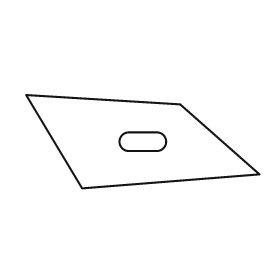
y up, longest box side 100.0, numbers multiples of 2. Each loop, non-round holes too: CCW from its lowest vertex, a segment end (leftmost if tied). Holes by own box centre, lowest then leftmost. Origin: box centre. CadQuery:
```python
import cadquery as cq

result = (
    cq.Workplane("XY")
    .moveTo(-26.0, -20.0)
    .lineTo(50.0, -14.0)
    .lineTo(16.0, 16.0)
    .lineTo(-50.0, 20.0)
    .close()
    .moveTo(-6.0, -4.0)
    .lineTo(6.0, -4.0)
    .threePointArc((10.0, 0.0), (6.0, 4.0))
    .lineTo(-6.0, 4.0)
    .threePointArc((-10.0, 0.0), (-6.0, -4.0))
    .close()
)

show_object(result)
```